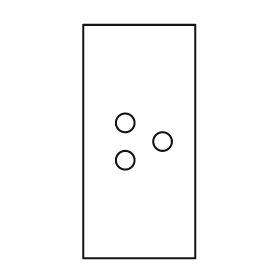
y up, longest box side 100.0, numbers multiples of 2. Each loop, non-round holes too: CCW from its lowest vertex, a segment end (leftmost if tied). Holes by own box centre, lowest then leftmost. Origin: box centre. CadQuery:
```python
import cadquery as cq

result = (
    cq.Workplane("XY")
    .moveTo(-24.0, -50.0)
    .lineTo(24.0, -50.0)
    .lineTo(24.0, 50.0)
    .lineTo(-24.0, 50.0)
    .close()
    .moveTo(-6.0, -8.0)
    .circle(4.0)
    .moveTo(10.0, 0.0)
    .circle(4.0)
    .moveTo(-6.0, 8.0)
    .circle(4.0)
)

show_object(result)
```